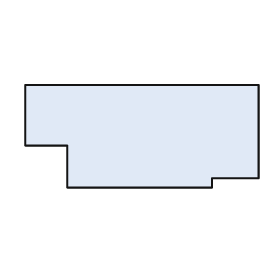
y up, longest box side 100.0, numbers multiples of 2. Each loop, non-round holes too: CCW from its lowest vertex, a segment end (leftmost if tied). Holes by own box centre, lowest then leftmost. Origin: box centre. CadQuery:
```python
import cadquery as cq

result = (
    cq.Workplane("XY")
    .moveTo(-32.0, -22.0)
    .lineTo(30.0, -22.0)
    .lineTo(30.0, -18.0)
    .lineTo(50.0, -18.0)
    .lineTo(50.0, 22.0)
    .lineTo(-50.0, 22.0)
    .lineTo(-50.0, -4.0)
    .lineTo(-32.0, -4.0)
    .close()
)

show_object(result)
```